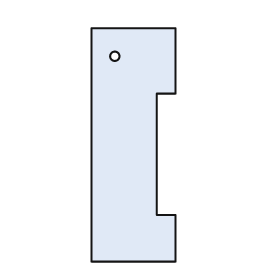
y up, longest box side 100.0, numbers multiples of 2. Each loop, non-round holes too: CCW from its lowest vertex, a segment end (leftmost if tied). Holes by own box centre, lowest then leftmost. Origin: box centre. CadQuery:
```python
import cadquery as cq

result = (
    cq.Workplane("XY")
    .moveTo(-18.0, -50.0)
    .lineTo(18.0, -50.0)
    .lineTo(18.0, -30.0)
    .lineTo(10.0, -30.0)
    .lineTo(10.0, 22.0)
    .lineTo(18.0, 22.0)
    .lineTo(18.0, 50.0)
    .lineTo(-18.0, 50.0)
    .close()
    .moveTo(-8.0, 38.0)
    .circle(2.0)
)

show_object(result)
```